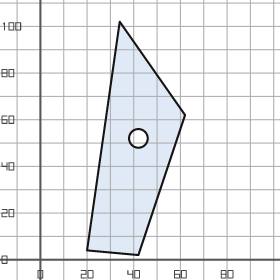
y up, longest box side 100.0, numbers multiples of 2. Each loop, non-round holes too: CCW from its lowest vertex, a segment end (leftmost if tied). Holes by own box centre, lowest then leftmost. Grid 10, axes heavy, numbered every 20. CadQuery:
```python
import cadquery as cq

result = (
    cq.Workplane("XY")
    .moveTo(42.0, 2.0)
    .lineTo(62.0, 62.0)
    .lineTo(34.0, 102.0)
    .lineTo(20.0, 4.0)
    .close()
    .moveTo(42.0, 52.0)
    .circle(4.0)
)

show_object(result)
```